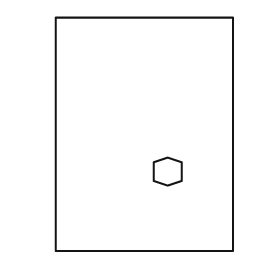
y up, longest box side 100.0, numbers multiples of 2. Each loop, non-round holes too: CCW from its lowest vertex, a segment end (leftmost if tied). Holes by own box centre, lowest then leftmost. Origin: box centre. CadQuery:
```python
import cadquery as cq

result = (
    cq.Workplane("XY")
    .moveTo(-38.0, -50.0)
    .lineTo(38.0, -50.0)
    .lineTo(38.0, 50.0)
    .lineTo(-38.0, 50.0)
    .close()
    .moveTo(10.0, -22.0)
    .lineTo(16.0, -20.0)
    .lineTo(16.0, -12.0)
    .lineTo(10.0, -10.0)
    .lineTo(4.0, -12.0)
    .lineTo(4.0, -20.0)
    .close()
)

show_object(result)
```